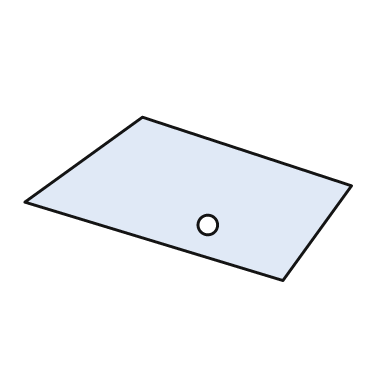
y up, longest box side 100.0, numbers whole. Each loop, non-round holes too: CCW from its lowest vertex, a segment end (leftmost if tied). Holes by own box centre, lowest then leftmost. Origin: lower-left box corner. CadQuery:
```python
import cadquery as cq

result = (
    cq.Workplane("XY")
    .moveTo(79.0, 0.0)
    .lineTo(100.0, 29.0)
    .lineTo(36.0, 50.0)
    .lineTo(0.0, 24.0)
    .close()
    .moveTo(56.0, 17.0)
    .circle(3.0)
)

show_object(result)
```